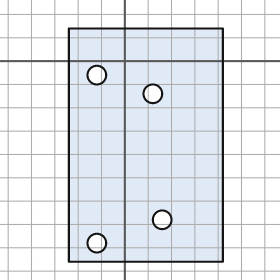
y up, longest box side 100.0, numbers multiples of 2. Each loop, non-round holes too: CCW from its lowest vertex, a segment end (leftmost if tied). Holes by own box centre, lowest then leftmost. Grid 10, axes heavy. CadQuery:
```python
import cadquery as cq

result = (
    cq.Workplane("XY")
    .moveTo(-24.0, -86.0)
    .lineTo(42.0, -86.0)
    .lineTo(42.0, 14.0)
    .lineTo(-24.0, 14.0)
    .close()
    .moveTo(-12.0, -78.0)
    .circle(4.0)
    .moveTo(16.0, -68.0)
    .circle(4.0)
    .moveTo(12.0, -14.0)
    .circle(4.0)
    .moveTo(-12.0, -6.0)
    .circle(4.0)
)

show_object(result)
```